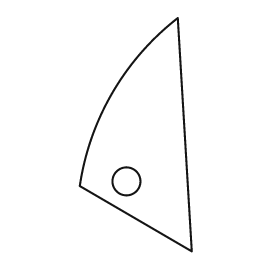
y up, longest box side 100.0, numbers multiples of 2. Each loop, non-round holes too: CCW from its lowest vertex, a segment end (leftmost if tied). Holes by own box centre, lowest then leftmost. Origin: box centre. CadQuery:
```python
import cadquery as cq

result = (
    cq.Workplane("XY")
    .moveTo(24.0, -50.0)
    .lineTo(18.0, 50.0)
    .threePointArc((-10.0, 18.0), (-24.0, -22.0))
    .close()
    .moveTo(-4.0, -20.0)
    .circle(6.0)
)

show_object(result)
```